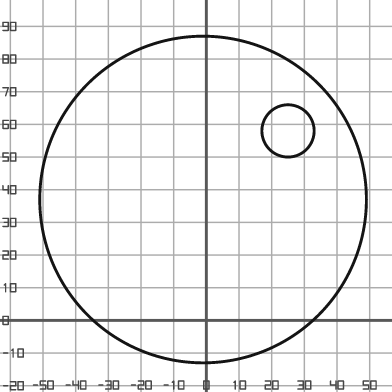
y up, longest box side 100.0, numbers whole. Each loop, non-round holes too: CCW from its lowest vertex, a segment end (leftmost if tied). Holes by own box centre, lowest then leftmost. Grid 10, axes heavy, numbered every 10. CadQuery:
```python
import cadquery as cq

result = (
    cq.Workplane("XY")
    .moveTo(-1.0, 37.0)
    .circle(50.0)
    .moveTo(25.0, 58.0)
    .circle(8.0)
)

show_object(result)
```